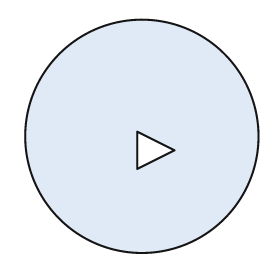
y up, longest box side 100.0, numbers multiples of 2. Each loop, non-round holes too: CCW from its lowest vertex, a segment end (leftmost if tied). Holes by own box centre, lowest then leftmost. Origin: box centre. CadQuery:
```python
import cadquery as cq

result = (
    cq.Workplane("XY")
    .moveTo(0.0, 0.0)
    .circle(50.0)
    .moveTo(-2.0, -14.0)
    .lineTo(14.0, -6.0)
    .lineTo(-2.0, 2.0)
    .close()
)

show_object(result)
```